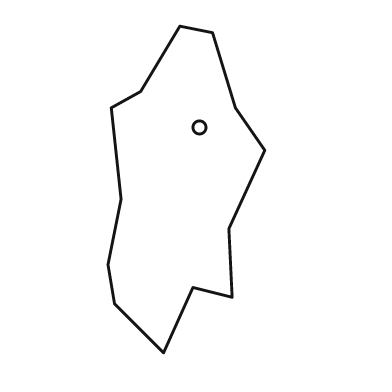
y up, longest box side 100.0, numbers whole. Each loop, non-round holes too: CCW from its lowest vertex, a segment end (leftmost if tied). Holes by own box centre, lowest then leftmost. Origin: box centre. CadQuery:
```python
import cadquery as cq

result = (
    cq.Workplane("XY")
    .moveTo(-7.0, -50.0)
    .lineTo(2.0, -30.0)
    .lineTo(14.0, -33.0)
    .lineTo(13.0, -12.0)
    .lineTo(24.0, 12.0)
    .lineTo(15.0, 25.0)
    .lineTo(8.0, 48.0)
    .lineTo(-2.0, 50.0)
    .lineTo(-14.0, 30.0)
    .lineTo(-23.0, 25.0)
    .lineTo(-20.0, -3.0)
    .lineTo(-24.0, -23.0)
    .lineTo(-22.0, -35.0)
    .close()
    .moveTo(4.0, 19.0)
    .circle(2.0)
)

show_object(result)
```